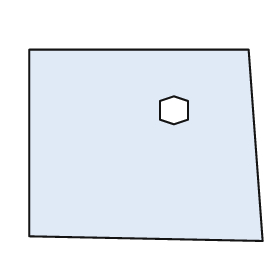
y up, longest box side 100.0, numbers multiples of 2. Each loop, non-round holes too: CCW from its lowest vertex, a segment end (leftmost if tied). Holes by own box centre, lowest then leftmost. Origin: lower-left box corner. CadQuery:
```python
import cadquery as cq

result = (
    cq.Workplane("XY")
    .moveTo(100.0, 0.0)
    .lineTo(94.0, 82.0)
    .lineTo(0.0, 82.0)
    .lineTo(0.0, 2.0)
    .close()
    .moveTo(62.0, 50.0)
    .lineTo(68.0, 52.0)
    .lineTo(68.0, 60.0)
    .lineTo(62.0, 62.0)
    .lineTo(56.0, 60.0)
    .lineTo(56.0, 52.0)
    .close()
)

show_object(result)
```